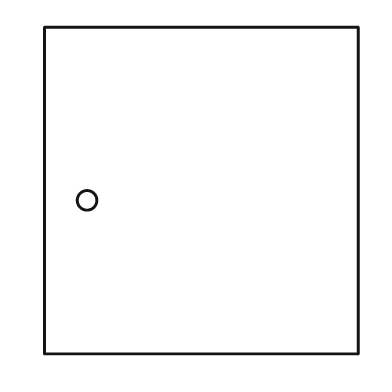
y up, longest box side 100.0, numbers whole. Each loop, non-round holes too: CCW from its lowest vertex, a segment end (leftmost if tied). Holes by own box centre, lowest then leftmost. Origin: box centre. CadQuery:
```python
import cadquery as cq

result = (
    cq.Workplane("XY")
    .moveTo(-48.0, -50.0)
    .lineTo(48.0, -50.0)
    .lineTo(48.0, 50.0)
    .lineTo(-48.0, 50.0)
    .close()
    .moveTo(-35.0, -3.0)
    .circle(3.0)
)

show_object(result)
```